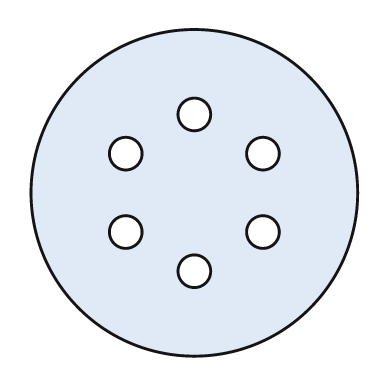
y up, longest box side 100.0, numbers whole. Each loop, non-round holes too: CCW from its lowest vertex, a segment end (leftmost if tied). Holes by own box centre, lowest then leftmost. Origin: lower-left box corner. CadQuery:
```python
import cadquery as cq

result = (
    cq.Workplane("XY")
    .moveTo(50.0, 50.0)
    .circle(50.0)
    .moveTo(50.0, 26.0)
    .circle(5.0)
    .moveTo(29.0, 38.0)
    .circle(5.0)
    .moveTo(71.0, 38.0)
    .circle(5.0)
    .moveTo(29.0, 62.0)
    .circle(5.0)
    .moveTo(71.0, 62.0)
    .circle(5.0)
    .moveTo(50.0, 74.0)
    .circle(5.0)
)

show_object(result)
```